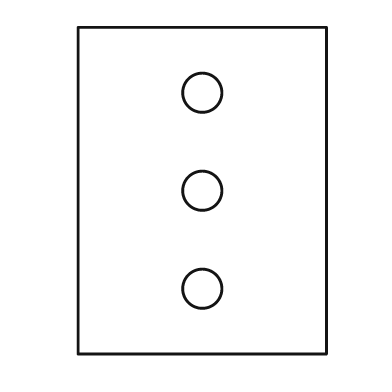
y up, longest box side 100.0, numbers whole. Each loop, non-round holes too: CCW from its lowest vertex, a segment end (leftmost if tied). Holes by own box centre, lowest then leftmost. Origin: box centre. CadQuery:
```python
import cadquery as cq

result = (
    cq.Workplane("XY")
    .moveTo(-38.0, -50.0)
    .lineTo(38.0, -50.0)
    .lineTo(38.0, 50.0)
    .lineTo(-38.0, 50.0)
    .close()
    .moveTo(0.0, -30.0)
    .circle(6.0)
    .moveTo(0.0, 0.0)
    .circle(6.0)
    .moveTo(0.0, 30.0)
    .circle(6.0)
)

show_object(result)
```